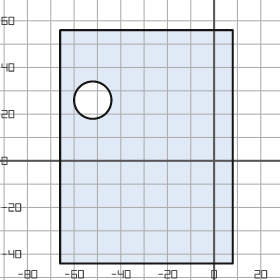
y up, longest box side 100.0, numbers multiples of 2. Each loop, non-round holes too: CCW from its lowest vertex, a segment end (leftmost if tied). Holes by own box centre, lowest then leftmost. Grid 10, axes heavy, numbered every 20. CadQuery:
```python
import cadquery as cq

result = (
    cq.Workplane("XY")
    .moveTo(-66.0, -44.0)
    .lineTo(8.0, -44.0)
    .lineTo(8.0, 56.0)
    .lineTo(-66.0, 56.0)
    .close()
    .moveTo(-52.0, 26.0)
    .circle(8.0)
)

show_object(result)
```